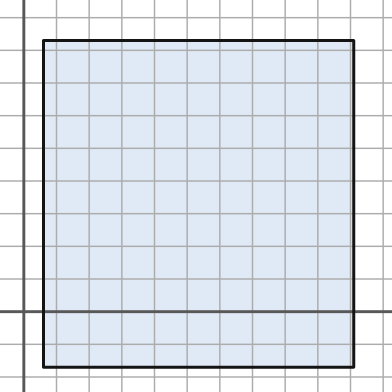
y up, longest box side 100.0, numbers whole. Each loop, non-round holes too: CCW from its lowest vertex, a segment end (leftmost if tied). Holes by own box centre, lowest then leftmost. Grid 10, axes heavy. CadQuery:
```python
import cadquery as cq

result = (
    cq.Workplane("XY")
    .moveTo(6.0, -17.0)
    .lineTo(101.0, -17.0)
    .lineTo(101.0, 83.0)
    .lineTo(6.0, 83.0)
    .close()
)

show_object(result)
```